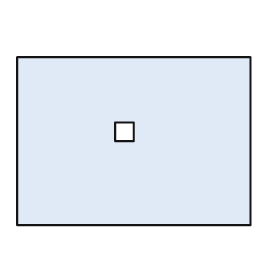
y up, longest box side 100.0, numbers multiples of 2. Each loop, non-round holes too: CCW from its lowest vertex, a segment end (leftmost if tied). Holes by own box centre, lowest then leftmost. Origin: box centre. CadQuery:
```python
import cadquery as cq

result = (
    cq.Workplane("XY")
    .moveTo(-50.0, -36.0)
    .lineTo(50.0, -36.0)
    .lineTo(50.0, 36.0)
    .lineTo(-50.0, 36.0)
    .close()
    .moveTo(-8.0, 0.0)
    .lineTo(0.0, 0.0)
    .lineTo(0.0, 8.0)
    .lineTo(-8.0, 8.0)
    .close()
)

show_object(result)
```